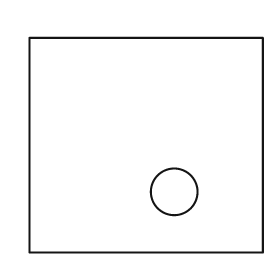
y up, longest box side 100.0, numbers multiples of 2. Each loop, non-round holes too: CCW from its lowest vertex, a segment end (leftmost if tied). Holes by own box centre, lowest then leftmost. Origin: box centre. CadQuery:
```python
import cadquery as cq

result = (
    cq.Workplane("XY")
    .moveTo(-50.0, -46.0)
    .lineTo(50.0, -46.0)
    .lineTo(50.0, 46.0)
    .lineTo(-50.0, 46.0)
    .close()
    .moveTo(12.0, -20.0)
    .circle(10.0)
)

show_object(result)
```